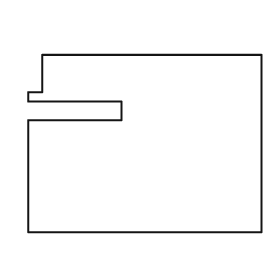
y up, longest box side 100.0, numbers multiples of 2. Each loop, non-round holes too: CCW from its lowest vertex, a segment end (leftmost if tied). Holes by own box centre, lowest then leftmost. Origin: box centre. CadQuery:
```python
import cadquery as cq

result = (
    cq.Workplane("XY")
    .moveTo(-50.0, -38.0)
    .lineTo(50.0, -38.0)
    .lineTo(50.0, 38.0)
    .lineTo(-44.0, 38.0)
    .lineTo(-44.0, 22.0)
    .lineTo(-50.0, 22.0)
    .lineTo(-50.0, 18.0)
    .lineTo(-10.0, 18.0)
    .lineTo(-10.0, 10.0)
    .lineTo(-50.0, 10.0)
    .close()
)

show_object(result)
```